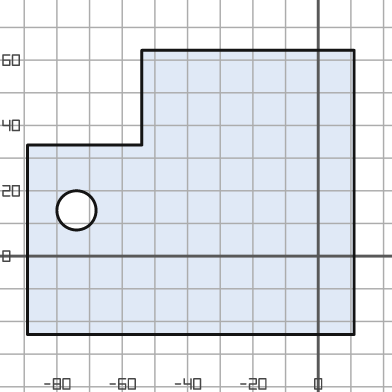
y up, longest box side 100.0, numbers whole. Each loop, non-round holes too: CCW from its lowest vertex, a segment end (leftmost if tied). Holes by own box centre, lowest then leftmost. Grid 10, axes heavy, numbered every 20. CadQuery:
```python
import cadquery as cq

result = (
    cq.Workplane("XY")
    .moveTo(-89.0, -24.0)
    .lineTo(11.0, -24.0)
    .lineTo(11.0, 63.0)
    .lineTo(-54.0, 63.0)
    .lineTo(-54.0, 34.0)
    .lineTo(-89.0, 34.0)
    .close()
    .moveTo(-74.0, 14.0)
    .circle(6.0)
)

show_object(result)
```